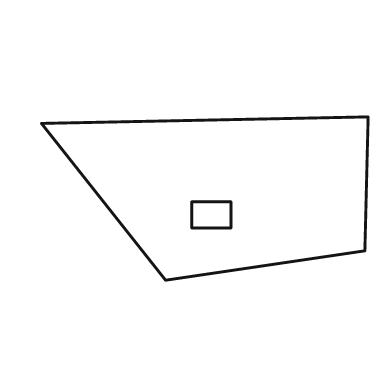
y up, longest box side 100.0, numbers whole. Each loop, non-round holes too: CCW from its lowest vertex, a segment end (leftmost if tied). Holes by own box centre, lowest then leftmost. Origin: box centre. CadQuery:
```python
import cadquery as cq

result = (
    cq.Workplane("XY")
    .moveTo(-12.0, -25.0)
    .lineTo(49.0, -16.0)
    .lineTo(50.0, 25.0)
    .lineTo(-50.0, 23.0)
    .close()
    .moveTo(-4.0, -9.0)
    .lineTo(8.0, -9.0)
    .lineTo(8.0, -1.0)
    .lineTo(-4.0, -1.0)
    .close()
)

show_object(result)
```